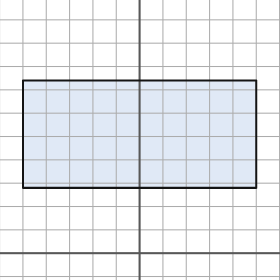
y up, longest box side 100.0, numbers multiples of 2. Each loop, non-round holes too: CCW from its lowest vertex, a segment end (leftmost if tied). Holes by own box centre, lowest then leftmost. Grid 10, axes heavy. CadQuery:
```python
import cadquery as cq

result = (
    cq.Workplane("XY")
    .moveTo(-50.0, 28.0)
    .lineTo(50.0, 28.0)
    .lineTo(50.0, 74.0)
    .lineTo(-50.0, 74.0)
    .close()
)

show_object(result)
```